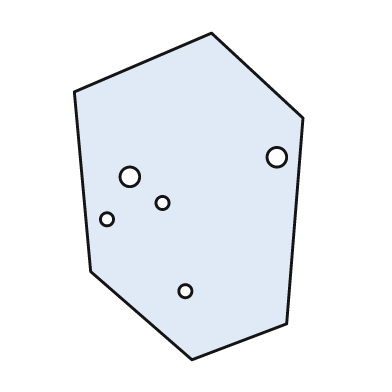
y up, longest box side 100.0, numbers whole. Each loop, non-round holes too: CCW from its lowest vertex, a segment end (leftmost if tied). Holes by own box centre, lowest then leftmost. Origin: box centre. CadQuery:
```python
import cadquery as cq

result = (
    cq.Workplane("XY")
    .moveTo(1.0, -50.0)
    .lineTo(30.0, -39.0)
    .lineTo(35.0, 24.0)
    .lineTo(7.0, 50.0)
    .lineTo(-35.0, 32.0)
    .lineTo(-30.0, -23.0)
    .close()
    .moveTo(-1.0, -29.0)
    .circle(2.0)
    .moveTo(-25.0, -7.0)
    .circle(2.0)
    .moveTo(-8.0, -2.0)
    .circle(2.0)
    .moveTo(-18.0, 6.0)
    .circle(3.0)
    .moveTo(27.0, 12.0)
    .circle(3.0)
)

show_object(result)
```